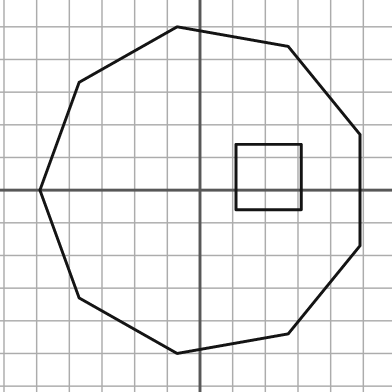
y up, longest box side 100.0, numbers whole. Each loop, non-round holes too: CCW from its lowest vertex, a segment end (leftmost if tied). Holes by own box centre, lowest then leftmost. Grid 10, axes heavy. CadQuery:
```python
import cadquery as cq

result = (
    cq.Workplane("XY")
    .moveTo(-7.0, -50.0)
    .lineTo(27.0, -44.0)
    .lineTo(49.0, -17.0)
    .lineTo(49.0, 17.0)
    .lineTo(27.0, 44.0)
    .lineTo(-7.0, 50.0)
    .lineTo(-37.0, 33.0)
    .lineTo(-49.0, 0.0)
    .lineTo(-37.0, -33.0)
    .close()
    .moveTo(11.0, -6.0)
    .lineTo(31.0, -6.0)
    .lineTo(31.0, 14.0)
    .lineTo(11.0, 14.0)
    .close()
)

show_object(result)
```